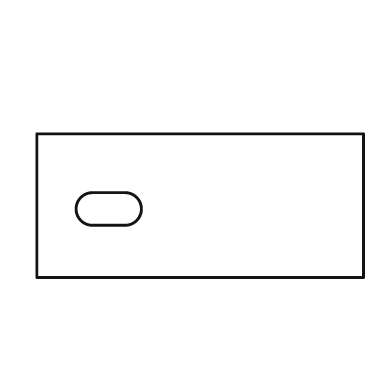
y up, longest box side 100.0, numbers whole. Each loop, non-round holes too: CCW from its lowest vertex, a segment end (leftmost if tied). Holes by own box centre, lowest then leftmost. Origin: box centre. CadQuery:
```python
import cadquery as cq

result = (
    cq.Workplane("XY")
    .moveTo(-50.0, -22.0)
    .lineTo(50.0, -22.0)
    .lineTo(50.0, 22.0)
    .lineTo(-50.0, 22.0)
    .close()
    .moveTo(-33.0, -6.0)
    .lineTo(-23.0, -6.0)
    .threePointArc((-18.0, -1.0), (-23.0, 4.0))
    .lineTo(-33.0, 4.0)
    .threePointArc((-38.0, -1.0), (-33.0, -6.0))
    .close()
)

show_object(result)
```